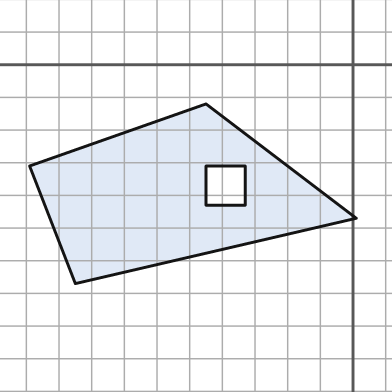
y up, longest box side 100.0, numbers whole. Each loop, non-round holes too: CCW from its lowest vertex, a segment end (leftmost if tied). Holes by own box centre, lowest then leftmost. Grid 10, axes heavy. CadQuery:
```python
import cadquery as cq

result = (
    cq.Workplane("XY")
    .moveTo(-85.0, -67.0)
    .lineTo(1.0, -47.0)
    .lineTo(-45.0, -12.0)
    .lineTo(-99.0, -31.0)
    .close()
    .moveTo(-45.0, -43.0)
    .lineTo(-33.0, -43.0)
    .lineTo(-33.0, -31.0)
    .lineTo(-45.0, -31.0)
    .close()
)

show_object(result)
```